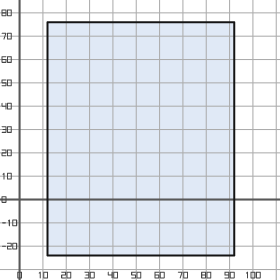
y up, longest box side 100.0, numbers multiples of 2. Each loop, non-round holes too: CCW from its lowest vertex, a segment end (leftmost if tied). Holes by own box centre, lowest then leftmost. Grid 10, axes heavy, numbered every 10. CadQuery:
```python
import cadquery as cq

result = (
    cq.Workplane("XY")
    .moveTo(12.0, -24.0)
    .lineTo(92.0, -24.0)
    .lineTo(92.0, 76.0)
    .lineTo(12.0, 76.0)
    .close()
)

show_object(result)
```